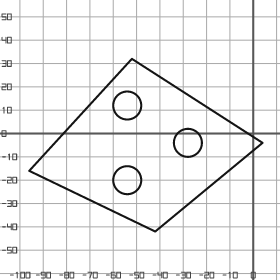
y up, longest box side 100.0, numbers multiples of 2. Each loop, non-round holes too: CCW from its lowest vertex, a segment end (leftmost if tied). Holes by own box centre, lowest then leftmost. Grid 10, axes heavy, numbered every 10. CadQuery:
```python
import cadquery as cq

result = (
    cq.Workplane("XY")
    .moveTo(-42.0, -42.0)
    .lineTo(4.0, -4.0)
    .lineTo(-52.0, 32.0)
    .lineTo(-96.0, -16.0)
    .close()
    .moveTo(-54.0, -20.0)
    .circle(6.0)
    .moveTo(-28.0, -4.0)
    .circle(6.0)
    .moveTo(-54.0, 12.0)
    .circle(6.0)
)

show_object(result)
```